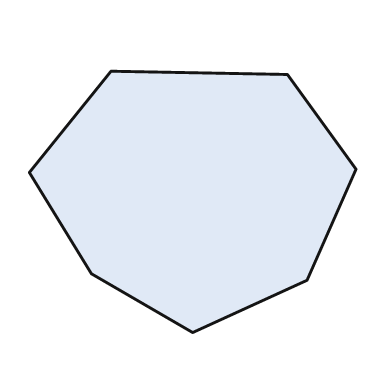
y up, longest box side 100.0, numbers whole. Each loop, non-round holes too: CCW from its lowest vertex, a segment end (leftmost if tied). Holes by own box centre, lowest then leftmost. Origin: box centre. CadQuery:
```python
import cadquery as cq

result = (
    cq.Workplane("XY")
    .moveTo(0.0, -40.0)
    .lineTo(35.0, -24.0)
    .lineTo(50.0, 10.0)
    .lineTo(29.0, 39.0)
    .lineTo(-25.0, 40.0)
    .lineTo(-50.0, 9.0)
    .lineTo(-31.0, -22.0)
    .close()
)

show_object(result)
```